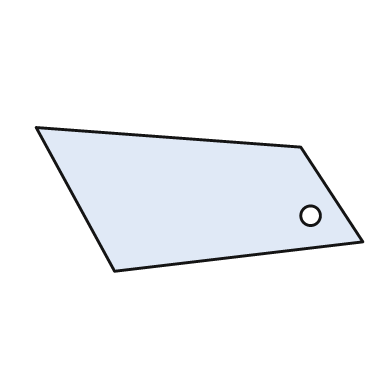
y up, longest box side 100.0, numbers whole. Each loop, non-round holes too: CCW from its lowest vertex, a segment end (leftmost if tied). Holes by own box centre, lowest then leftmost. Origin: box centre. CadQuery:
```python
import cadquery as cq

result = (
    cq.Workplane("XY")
    .moveTo(-26.0, -22.0)
    .lineTo(50.0, -13.0)
    .lineTo(31.0, 16.0)
    .lineTo(-50.0, 22.0)
    .close()
    .moveTo(34.0, -5.0)
    .circle(3.0)
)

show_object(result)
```